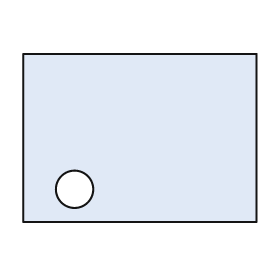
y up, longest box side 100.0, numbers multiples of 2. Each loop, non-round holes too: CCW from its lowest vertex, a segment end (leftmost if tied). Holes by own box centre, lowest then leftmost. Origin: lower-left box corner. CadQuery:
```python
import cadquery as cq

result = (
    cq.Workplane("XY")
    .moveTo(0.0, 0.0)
    .lineTo(100.0, 0.0)
    .lineTo(100.0, 72.0)
    .lineTo(0.0, 72.0)
    .close()
    .moveTo(22.0, 14.0)
    .circle(8.0)
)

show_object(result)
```